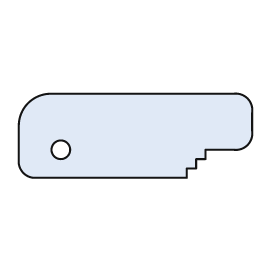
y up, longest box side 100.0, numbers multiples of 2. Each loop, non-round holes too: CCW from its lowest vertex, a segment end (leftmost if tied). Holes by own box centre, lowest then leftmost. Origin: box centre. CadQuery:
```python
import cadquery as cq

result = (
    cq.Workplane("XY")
    .moveTo(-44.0, -18.0)
    .lineTo(22.0, -18.0)
    .lineTo(22.0, -14.0)
    .lineTo(26.0, -14.0)
    .lineTo(26.0, -10.0)
    .lineTo(30.0, -10.0)
    .lineTo(30.0, -6.0)
    .lineTo(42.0, -6.0)
    .threePointArc((48.0, -4.0), (50.0, 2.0))
    .lineTo(50.0, 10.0)
    .threePointArc((48.0, 16.0), (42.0, 18.0))
    .lineTo(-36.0, 18.0)
    .threePointArc((-46.0, 14.0), (-50.0, 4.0))
    .lineTo(-50.0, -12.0)
    .threePointArc((-48.0, -16.0), (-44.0, -18.0))
    .close()
    .moveTo(-32.0, -6.0)
    .circle(4.0)
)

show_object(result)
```